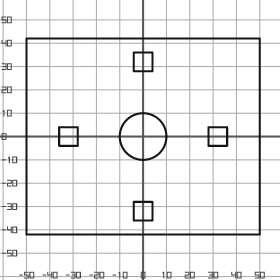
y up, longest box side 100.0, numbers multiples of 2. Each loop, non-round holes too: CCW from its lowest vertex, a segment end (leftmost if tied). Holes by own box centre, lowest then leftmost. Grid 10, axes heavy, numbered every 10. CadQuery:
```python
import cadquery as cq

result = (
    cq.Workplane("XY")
    .moveTo(-50.0, -42.0)
    .lineTo(50.0, -42.0)
    .lineTo(50.0, 42.0)
    .lineTo(-50.0, 42.0)
    .close()
    .moveTo(-4.0, -36.0)
    .lineTo(4.0, -36.0)
    .lineTo(4.0, -28.0)
    .lineTo(-4.0, -28.0)
    .close()
    .moveTo(-36.0, -4.0)
    .lineTo(-28.0, -4.0)
    .lineTo(-28.0, 4.0)
    .lineTo(-36.0, 4.0)
    .close()
    .moveTo(0.0, 0.0)
    .circle(10.0)
    .moveTo(28.0, -4.0)
    .lineTo(36.0, -4.0)
    .lineTo(36.0, 4.0)
    .lineTo(28.0, 4.0)
    .close()
    .moveTo(-4.0, 28.0)
    .lineTo(4.0, 28.0)
    .lineTo(4.0, 36.0)
    .lineTo(-4.0, 36.0)
    .close()
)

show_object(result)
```